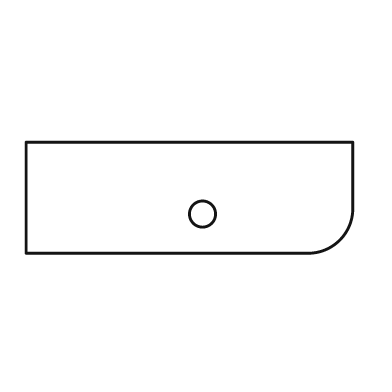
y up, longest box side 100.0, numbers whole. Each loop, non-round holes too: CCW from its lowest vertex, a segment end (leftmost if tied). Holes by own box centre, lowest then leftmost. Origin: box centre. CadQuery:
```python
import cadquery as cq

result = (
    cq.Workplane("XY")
    .moveTo(-50.0, -17.0)
    .lineTo(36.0, -17.0)
    .threePointArc((46.0, -13.0), (50.0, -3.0))
    .lineTo(50.0, 17.0)
    .lineTo(-50.0, 17.0)
    .close()
    .moveTo(4.0, -5.0)
    .circle(4.0)
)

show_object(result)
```